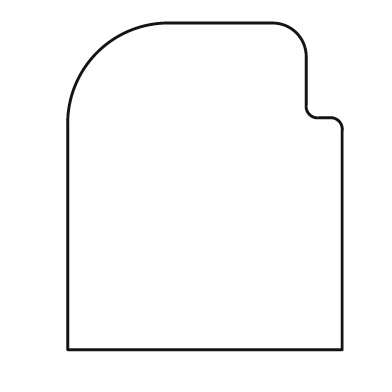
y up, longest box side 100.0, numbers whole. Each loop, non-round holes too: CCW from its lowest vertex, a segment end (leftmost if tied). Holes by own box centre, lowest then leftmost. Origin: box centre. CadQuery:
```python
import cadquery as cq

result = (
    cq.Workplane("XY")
    .moveTo(-42.0, -50.0)
    .lineTo(42.0, -50.0)
    .lineTo(42.0, 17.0)
    .threePointArc((41.0, 20.0), (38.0, 21.0))
    .lineTo(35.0, 21.0)
    .threePointArc((32.0, 22.0), (31.0, 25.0))
    .lineTo(31.0, 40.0)
    .threePointArc((28.0, 47.0), (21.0, 50.0))
    .lineTo(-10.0, 50.0)
    .threePointArc((-33.0, 41.0), (-42.0, 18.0))
    .close()
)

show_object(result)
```